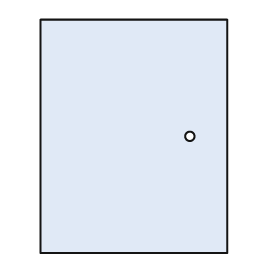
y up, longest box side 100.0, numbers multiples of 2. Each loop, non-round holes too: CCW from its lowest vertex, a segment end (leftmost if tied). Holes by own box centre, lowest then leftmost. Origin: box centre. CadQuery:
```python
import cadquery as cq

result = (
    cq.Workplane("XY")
    .moveTo(-40.0, -50.0)
    .lineTo(40.0, -50.0)
    .lineTo(40.0, 50.0)
    .lineTo(-40.0, 50.0)
    .close()
    .moveTo(24.0, 0.0)
    .circle(2.0)
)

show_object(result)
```